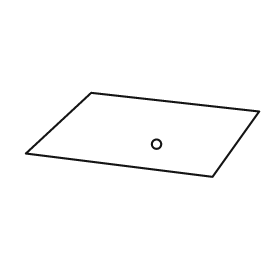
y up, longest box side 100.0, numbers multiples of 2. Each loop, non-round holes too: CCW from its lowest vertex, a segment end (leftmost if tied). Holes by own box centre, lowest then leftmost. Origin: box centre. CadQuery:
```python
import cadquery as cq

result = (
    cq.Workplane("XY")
    .moveTo(30.0, -18.0)
    .lineTo(50.0, 10.0)
    .lineTo(-22.0, 18.0)
    .lineTo(-50.0, -8.0)
    .close()
    .moveTo(6.0, -4.0)
    .circle(2.0)
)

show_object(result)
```